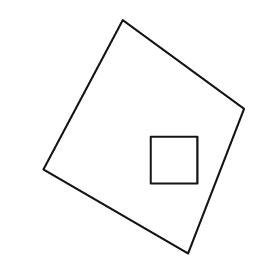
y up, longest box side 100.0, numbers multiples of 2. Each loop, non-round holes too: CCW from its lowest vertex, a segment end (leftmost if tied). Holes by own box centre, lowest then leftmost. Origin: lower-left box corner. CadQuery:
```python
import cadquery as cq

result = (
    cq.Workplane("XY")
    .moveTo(62.0, 0.0)
    .lineTo(86.0, 62.0)
    .lineTo(34.0, 100.0)
    .lineTo(0.0, 36.0)
    .close()
    .moveTo(46.0, 30.0)
    .lineTo(66.0, 30.0)
    .lineTo(66.0, 50.0)
    .lineTo(46.0, 50.0)
    .close()
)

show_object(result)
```